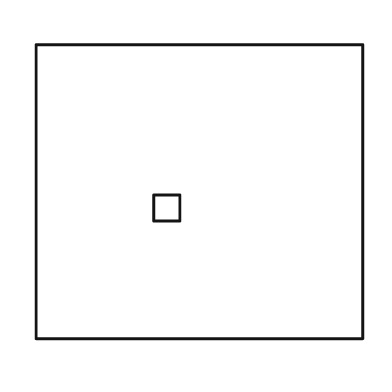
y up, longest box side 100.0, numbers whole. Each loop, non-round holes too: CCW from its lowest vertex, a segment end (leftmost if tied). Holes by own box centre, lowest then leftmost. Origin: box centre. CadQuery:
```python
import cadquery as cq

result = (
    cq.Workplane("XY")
    .moveTo(-50.0, -45.0)
    .lineTo(50.0, -45.0)
    .lineTo(50.0, 45.0)
    .lineTo(-50.0, 45.0)
    .close()
    .moveTo(-14.0, -9.0)
    .lineTo(-6.0, -9.0)
    .lineTo(-6.0, -1.0)
    .lineTo(-14.0, -1.0)
    .close()
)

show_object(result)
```